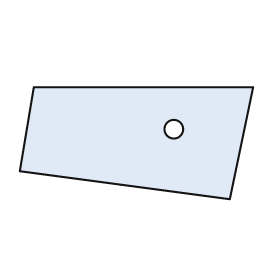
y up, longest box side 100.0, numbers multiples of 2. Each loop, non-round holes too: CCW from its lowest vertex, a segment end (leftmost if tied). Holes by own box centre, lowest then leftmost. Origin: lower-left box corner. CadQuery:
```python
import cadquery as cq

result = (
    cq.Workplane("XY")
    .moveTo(90.0, 0.0)
    .lineTo(100.0, 48.0)
    .lineTo(6.0, 48.0)
    .lineTo(0.0, 12.0)
    .close()
    .moveTo(66.0, 30.0)
    .circle(4.0)
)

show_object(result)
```